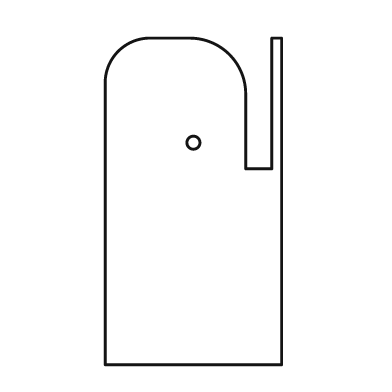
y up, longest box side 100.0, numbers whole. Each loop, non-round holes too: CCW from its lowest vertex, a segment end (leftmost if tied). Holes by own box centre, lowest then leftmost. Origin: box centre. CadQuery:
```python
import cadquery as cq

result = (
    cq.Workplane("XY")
    .moveTo(-27.0, -50.0)
    .lineTo(27.0, -50.0)
    .lineTo(27.0, 50.0)
    .lineTo(24.0, 50.0)
    .lineTo(24.0, 10.0)
    .lineTo(16.0, 10.0)
    .lineTo(16.0, 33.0)
    .threePointArc((11.0, 45.0), (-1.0, 50.0))
    .lineTo(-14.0, 50.0)
    .threePointArc((-23.0, 46.0), (-27.0, 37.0))
    .close()
    .moveTo(0.0, 18.0)
    .circle(2.0)
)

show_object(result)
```